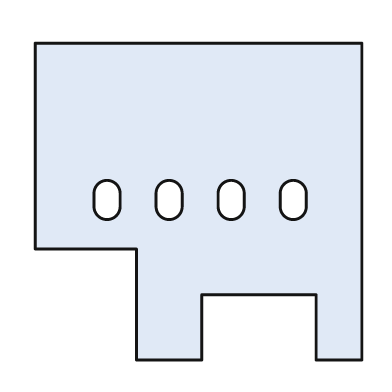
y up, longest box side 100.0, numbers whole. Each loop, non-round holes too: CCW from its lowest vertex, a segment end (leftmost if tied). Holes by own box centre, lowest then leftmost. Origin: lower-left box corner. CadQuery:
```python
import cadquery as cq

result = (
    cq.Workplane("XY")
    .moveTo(31.0, 0.0)
    .lineTo(51.0, 0.0)
    .lineTo(51.0, 20.0)
    .lineTo(86.0, 20.0)
    .lineTo(86.0, 0.0)
    .lineTo(100.0, 0.0)
    .lineTo(100.0, 97.0)
    .lineTo(0.0, 97.0)
    .lineTo(0.0, 34.0)
    .lineTo(31.0, 34.0)
    .close()
    .moveTo(18.0, 47.0)
    .threePointArc((22.0, 43.0), (26.0, 47.0))
    .lineTo(26.0, 51.0)
    .threePointArc((22.0, 55.0), (18.0, 51.0))
    .close()
    .moveTo(37.0, 47.0)
    .threePointArc((41.0, 43.0), (45.0, 47.0))
    .lineTo(45.0, 51.0)
    .threePointArc((41.0, 55.0), (37.0, 51.0))
    .close()
    .moveTo(56.0, 47.0)
    .threePointArc((60.0, 43.0), (64.0, 47.0))
    .lineTo(64.0, 51.0)
    .threePointArc((60.0, 55.0), (56.0, 51.0))
    .close()
    .moveTo(75.0, 47.0)
    .threePointArc((79.0, 43.0), (83.0, 47.0))
    .lineTo(83.0, 51.0)
    .threePointArc((79.0, 55.0), (75.0, 51.0))
    .close()
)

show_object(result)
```